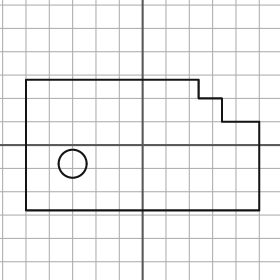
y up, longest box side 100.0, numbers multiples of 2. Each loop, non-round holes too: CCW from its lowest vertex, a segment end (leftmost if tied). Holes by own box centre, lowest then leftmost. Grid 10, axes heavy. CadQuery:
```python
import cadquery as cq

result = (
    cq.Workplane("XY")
    .moveTo(-50.0, -28.0)
    .lineTo(50.0, -28.0)
    .lineTo(50.0, 10.0)
    .lineTo(34.0, 10.0)
    .lineTo(34.0, 20.0)
    .lineTo(24.0, 20.0)
    .lineTo(24.0, 28.0)
    .lineTo(-50.0, 28.0)
    .close()
    .moveTo(-30.0, -8.0)
    .circle(6.0)
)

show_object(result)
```